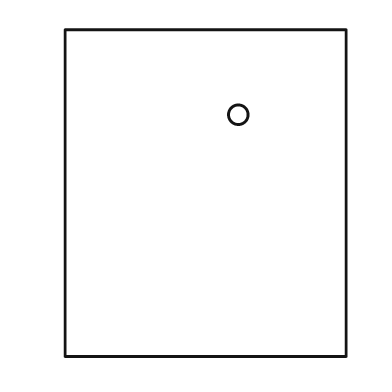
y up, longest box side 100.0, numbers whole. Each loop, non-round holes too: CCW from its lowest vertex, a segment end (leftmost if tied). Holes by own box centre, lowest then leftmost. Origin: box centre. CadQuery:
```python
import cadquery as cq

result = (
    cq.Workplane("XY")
    .moveTo(-43.0, -50.0)
    .lineTo(43.0, -50.0)
    .lineTo(43.0, 50.0)
    .lineTo(-43.0, 50.0)
    .close()
    .moveTo(10.0, 24.0)
    .circle(3.0)
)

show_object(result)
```